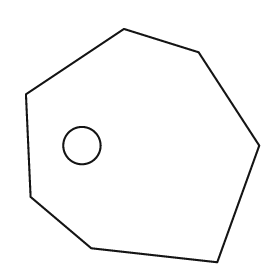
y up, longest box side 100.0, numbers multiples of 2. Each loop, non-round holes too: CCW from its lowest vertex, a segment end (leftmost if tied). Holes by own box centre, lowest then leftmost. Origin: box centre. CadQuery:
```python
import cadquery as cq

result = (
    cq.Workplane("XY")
    .moveTo(32.0, -50.0)
    .lineTo(50.0, 0.0)
    .lineTo(24.0, 40.0)
    .lineTo(-8.0, 50.0)
    .lineTo(-50.0, 22.0)
    .lineTo(-48.0, -22.0)
    .lineTo(-22.0, -44.0)
    .close()
    .moveTo(-26.0, 0.0)
    .circle(8.0)
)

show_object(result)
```